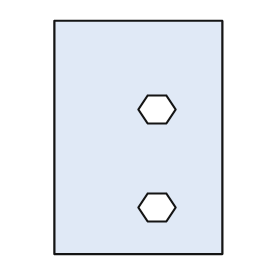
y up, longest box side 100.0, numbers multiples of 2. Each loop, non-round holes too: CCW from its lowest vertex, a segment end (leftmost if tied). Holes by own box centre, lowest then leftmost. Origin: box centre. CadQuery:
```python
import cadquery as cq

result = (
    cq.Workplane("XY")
    .moveTo(-36.0, -50.0)
    .lineTo(36.0, -50.0)
    .lineTo(36.0, 50.0)
    .lineTo(-36.0, 50.0)
    .close()
    .moveTo(4.0, -36.0)
    .lineTo(12.0, -36.0)
    .lineTo(16.0, -30.0)
    .lineTo(12.0, -24.0)
    .lineTo(4.0, -24.0)
    .lineTo(0.0, -30.0)
    .close()
    .moveTo(4.0, 6.0)
    .lineTo(12.0, 6.0)
    .lineTo(16.0, 12.0)
    .lineTo(12.0, 18.0)
    .lineTo(4.0, 18.0)
    .lineTo(0.0, 12.0)
    .close()
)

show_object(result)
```